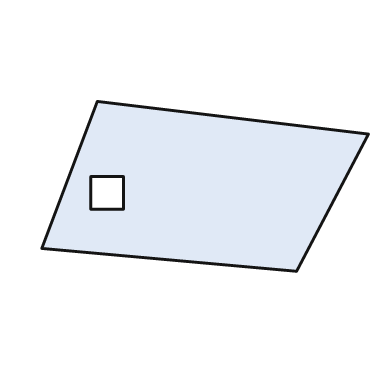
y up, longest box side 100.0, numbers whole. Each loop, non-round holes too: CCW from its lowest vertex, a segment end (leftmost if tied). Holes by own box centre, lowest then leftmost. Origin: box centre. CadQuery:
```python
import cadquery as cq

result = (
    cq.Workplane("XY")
    .moveTo(28.0, -26.0)
    .lineTo(50.0, 16.0)
    .lineTo(-33.0, 26.0)
    .lineTo(-50.0, -19.0)
    .close()
    .moveTo(-35.0, -7.0)
    .lineTo(-25.0, -7.0)
    .lineTo(-25.0, 3.0)
    .lineTo(-35.0, 3.0)
    .close()
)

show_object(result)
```